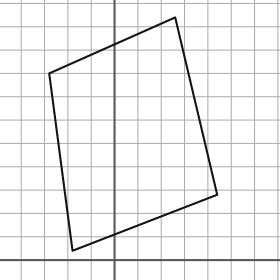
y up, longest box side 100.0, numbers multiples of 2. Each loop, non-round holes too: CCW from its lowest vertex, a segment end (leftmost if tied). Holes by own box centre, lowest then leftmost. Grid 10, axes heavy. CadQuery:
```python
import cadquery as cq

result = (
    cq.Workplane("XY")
    .moveTo(-18.0, 4.0)
    .lineTo(44.0, 28.0)
    .lineTo(26.0, 104.0)
    .lineTo(-28.0, 80.0)
    .close()
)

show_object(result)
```